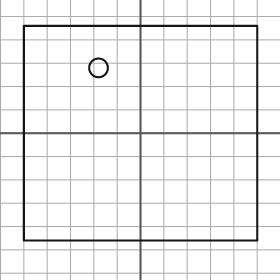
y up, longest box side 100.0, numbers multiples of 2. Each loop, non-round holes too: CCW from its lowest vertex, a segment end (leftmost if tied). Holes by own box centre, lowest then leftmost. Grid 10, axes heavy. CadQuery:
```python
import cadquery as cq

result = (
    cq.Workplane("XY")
    .moveTo(-50.0, -46.0)
    .lineTo(50.0, -46.0)
    .lineTo(50.0, 46.0)
    .lineTo(-50.0, 46.0)
    .close()
    .moveTo(-18.0, 28.0)
    .circle(4.0)
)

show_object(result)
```